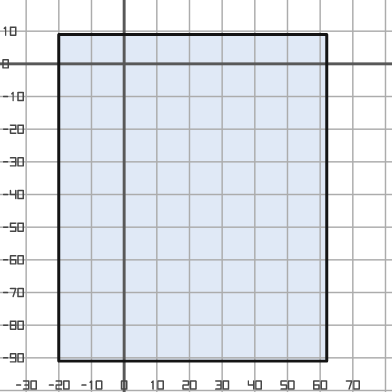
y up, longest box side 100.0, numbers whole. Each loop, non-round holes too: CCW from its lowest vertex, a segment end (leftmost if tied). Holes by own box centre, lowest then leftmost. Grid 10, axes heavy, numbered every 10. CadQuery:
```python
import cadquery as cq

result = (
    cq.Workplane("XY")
    .moveTo(-20.0, -91.0)
    .lineTo(62.0, -91.0)
    .lineTo(62.0, 9.0)
    .lineTo(-20.0, 9.0)
    .close()
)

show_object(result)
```